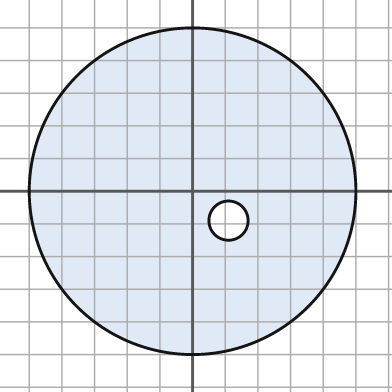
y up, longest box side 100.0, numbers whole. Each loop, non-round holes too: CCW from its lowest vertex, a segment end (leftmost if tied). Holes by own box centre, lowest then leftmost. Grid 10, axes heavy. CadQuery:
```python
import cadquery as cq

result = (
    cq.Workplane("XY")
    .moveTo(0.0, 0.0)
    .circle(50.0)
    .moveTo(11.0, -9.0)
    .circle(6.0)
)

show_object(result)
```